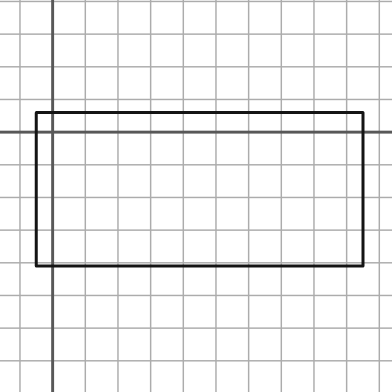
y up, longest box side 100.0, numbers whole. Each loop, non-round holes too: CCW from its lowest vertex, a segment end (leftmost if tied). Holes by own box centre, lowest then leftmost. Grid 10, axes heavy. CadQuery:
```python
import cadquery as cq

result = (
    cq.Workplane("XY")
    .moveTo(-5.0, -41.0)
    .lineTo(95.0, -41.0)
    .lineTo(95.0, 6.0)
    .lineTo(-5.0, 6.0)
    .close()
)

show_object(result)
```